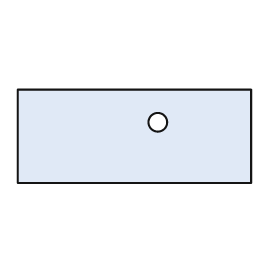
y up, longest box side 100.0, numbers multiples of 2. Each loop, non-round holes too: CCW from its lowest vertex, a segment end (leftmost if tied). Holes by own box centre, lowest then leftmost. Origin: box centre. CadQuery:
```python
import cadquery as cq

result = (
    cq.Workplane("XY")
    .moveTo(-50.0, -20.0)
    .lineTo(50.0, -20.0)
    .lineTo(50.0, 20.0)
    .lineTo(-50.0, 20.0)
    .close()
    .moveTo(10.0, 6.0)
    .circle(4.0)
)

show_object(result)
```